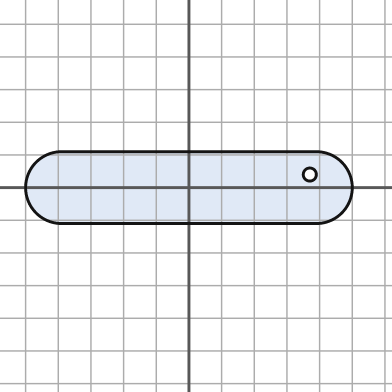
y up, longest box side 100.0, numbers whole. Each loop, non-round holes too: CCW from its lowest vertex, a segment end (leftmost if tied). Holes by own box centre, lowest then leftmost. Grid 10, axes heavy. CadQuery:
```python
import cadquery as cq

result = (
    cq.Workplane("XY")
    .moveTo(-39.0, -11.0)
    .lineTo(39.0, -11.0)
    .threePointArc((50.0, 0.0), (39.0, 11.0))
    .lineTo(-39.0, 11.0)
    .threePointArc((-50.0, 0.0), (-39.0, -11.0))
    .close()
    .moveTo(37.0, 4.0)
    .circle(2.0)
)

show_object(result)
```